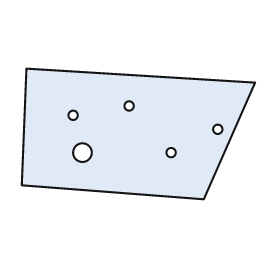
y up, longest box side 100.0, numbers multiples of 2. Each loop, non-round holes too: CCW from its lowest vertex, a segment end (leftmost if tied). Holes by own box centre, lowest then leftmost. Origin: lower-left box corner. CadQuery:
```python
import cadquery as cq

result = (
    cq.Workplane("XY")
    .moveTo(78.0, 0.0)
    .lineTo(100.0, 50.0)
    .lineTo(2.0, 56.0)
    .lineTo(0.0, 6.0)
    .close()
    .moveTo(26.0, 20.0)
    .circle(4.0)
    .moveTo(64.0, 20.0)
    .circle(2.0)
    .moveTo(84.0, 30.0)
    .circle(2.0)
    .moveTo(22.0, 36.0)
    .circle(2.0)
    .moveTo(46.0, 40.0)
    .circle(2.0)
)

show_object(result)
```